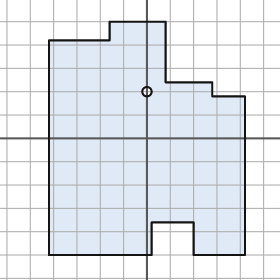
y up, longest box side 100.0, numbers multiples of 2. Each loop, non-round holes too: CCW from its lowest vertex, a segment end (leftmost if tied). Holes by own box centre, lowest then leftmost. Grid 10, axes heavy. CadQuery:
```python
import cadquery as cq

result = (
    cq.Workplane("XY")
    .moveTo(-42.0, -50.0)
    .lineTo(2.0, -50.0)
    .lineTo(2.0, -36.0)
    .lineTo(20.0, -36.0)
    .lineTo(20.0, -50.0)
    .lineTo(42.0, -50.0)
    .lineTo(42.0, 18.0)
    .lineTo(28.0, 18.0)
    .lineTo(28.0, 24.0)
    .lineTo(8.0, 24.0)
    .lineTo(8.0, 50.0)
    .lineTo(-16.0, 50.0)
    .lineTo(-16.0, 42.0)
    .lineTo(-42.0, 42.0)
    .close()
    .moveTo(0.0, 20.0)
    .circle(2.0)
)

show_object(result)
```